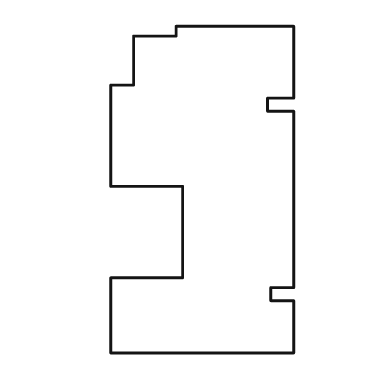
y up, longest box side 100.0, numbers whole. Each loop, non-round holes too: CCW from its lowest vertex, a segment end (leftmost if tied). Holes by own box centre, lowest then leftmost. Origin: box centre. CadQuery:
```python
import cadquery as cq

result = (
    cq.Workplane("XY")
    .moveTo(-28.0, -50.0)
    .lineTo(28.0, -50.0)
    .lineTo(28.0, -34.0)
    .lineTo(21.0, -34.0)
    .lineTo(21.0, -30.0)
    .lineTo(28.0, -30.0)
    .lineTo(28.0, 24.0)
    .lineTo(20.0, 24.0)
    .lineTo(20.0, 28.0)
    .lineTo(28.0, 28.0)
    .lineTo(28.0, 50.0)
    .lineTo(-8.0, 50.0)
    .lineTo(-8.0, 47.0)
    .lineTo(-21.0, 47.0)
    .lineTo(-21.0, 32.0)
    .lineTo(-28.0, 32.0)
    .lineTo(-28.0, 1.0)
    .lineTo(-6.0, 1.0)
    .lineTo(-6.0, -27.0)
    .lineTo(-28.0, -27.0)
    .close()
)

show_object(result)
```